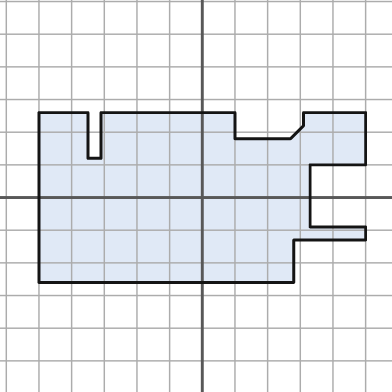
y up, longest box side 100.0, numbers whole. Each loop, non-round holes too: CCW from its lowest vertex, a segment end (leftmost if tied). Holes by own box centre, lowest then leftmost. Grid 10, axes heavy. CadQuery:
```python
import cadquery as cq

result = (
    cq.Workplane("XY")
    .moveTo(-50.0, -26.0)
    .lineTo(28.0, -26.0)
    .lineTo(28.0, -13.0)
    .lineTo(50.0, -13.0)
    .lineTo(50.0, -9.0)
    .lineTo(33.0, -9.0)
    .lineTo(33.0, 10.0)
    .lineTo(50.0, 10.0)
    .lineTo(50.0, 26.0)
    .lineTo(31.0, 26.0)
    .lineTo(31.0, 22.0)
    .lineTo(27.0, 18.0)
    .lineTo(10.0, 18.0)
    .lineTo(10.0, 26.0)
    .lineTo(-31.0, 26.0)
    .lineTo(-31.0, 12.0)
    .lineTo(-35.0, 12.0)
    .lineTo(-35.0, 26.0)
    .lineTo(-50.0, 26.0)
    .close()
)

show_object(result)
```